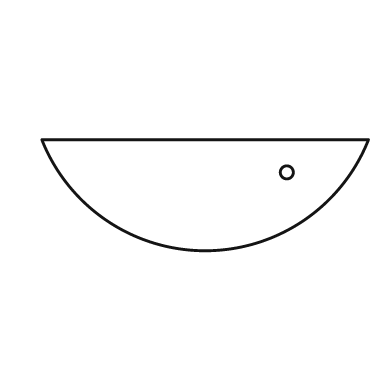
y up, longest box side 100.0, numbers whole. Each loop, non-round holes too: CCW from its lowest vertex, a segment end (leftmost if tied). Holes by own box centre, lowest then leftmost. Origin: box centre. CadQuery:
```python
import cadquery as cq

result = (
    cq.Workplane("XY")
    .moveTo(-50.0, 17.0)
    .threePointArc((0.0, -17.0), (50.0, 17.0))
    .close()
    .moveTo(25.0, 7.0)
    .circle(2.0)
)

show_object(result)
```